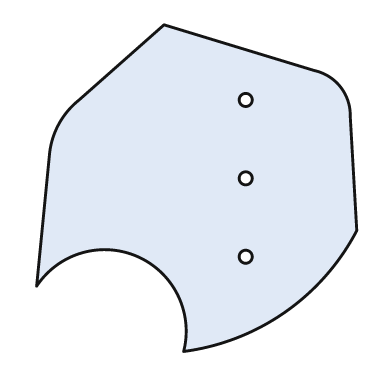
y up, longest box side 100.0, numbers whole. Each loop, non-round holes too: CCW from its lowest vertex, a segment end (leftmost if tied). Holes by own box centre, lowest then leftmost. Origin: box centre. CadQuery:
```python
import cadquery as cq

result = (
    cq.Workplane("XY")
    .moveTo(-4.0, -50.0)
    .threePointArc((27.0, -38.0), (49.0, -13.0))
    .lineTo(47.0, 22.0)
    .threePointArc((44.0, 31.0), (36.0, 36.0))
    .lineTo(-10.0, 50.0)
    .lineTo(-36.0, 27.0)
    .threePointArc((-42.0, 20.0), (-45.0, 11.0))
    .lineTo(-49.0, -30.0)
    .threePointArc((-18.0, -21.0), (-4.0, -50.0))
    .close()
    .moveTo(15.0, -21.0)
    .circle(2.0)
    .moveTo(15.0, 3.0)
    .circle(2.0)
    .moveTo(15.0, 27.0)
    .circle(2.0)
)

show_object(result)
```